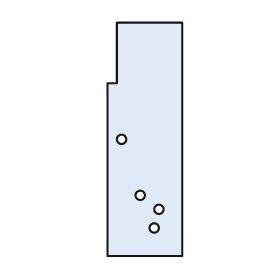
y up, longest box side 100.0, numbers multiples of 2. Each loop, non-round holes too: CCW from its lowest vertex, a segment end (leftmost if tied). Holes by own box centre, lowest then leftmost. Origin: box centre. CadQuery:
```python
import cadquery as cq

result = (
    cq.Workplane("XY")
    .moveTo(-16.0, -50.0)
    .lineTo(16.0, -50.0)
    .lineTo(16.0, 50.0)
    .lineTo(-12.0, 50.0)
    .lineTo(-12.0, 24.0)
    .lineTo(-16.0, 24.0)
    .close()
    .moveTo(4.0, -38.0)
    .circle(2.0)
    .moveTo(6.0, -30.0)
    .circle(2.0)
    .moveTo(-2.0, -24.0)
    .circle(2.0)
    .moveTo(-10.0, 0.0)
    .circle(2.0)
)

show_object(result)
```